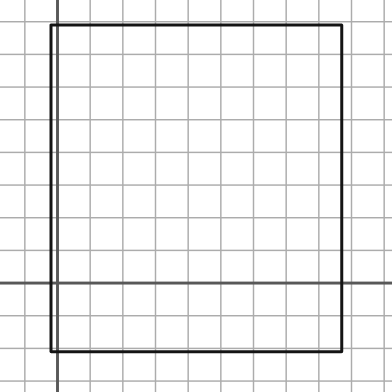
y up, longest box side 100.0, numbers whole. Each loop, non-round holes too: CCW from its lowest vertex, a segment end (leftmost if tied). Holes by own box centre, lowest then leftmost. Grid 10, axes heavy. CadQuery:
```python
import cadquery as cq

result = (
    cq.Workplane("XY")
    .moveTo(-2.0, -21.0)
    .lineTo(87.0, -21.0)
    .lineTo(87.0, 79.0)
    .lineTo(-2.0, 79.0)
    .close()
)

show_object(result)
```